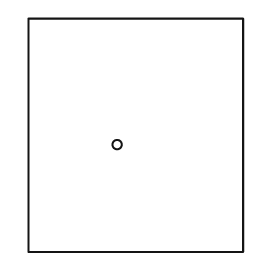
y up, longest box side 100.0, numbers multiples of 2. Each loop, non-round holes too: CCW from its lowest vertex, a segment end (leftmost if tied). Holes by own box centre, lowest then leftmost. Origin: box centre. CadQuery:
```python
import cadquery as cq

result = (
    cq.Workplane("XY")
    .moveTo(-46.0, -50.0)
    .lineTo(46.0, -50.0)
    .lineTo(46.0, 50.0)
    .lineTo(-46.0, 50.0)
    .close()
    .moveTo(-8.0, -4.0)
    .circle(2.0)
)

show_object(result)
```